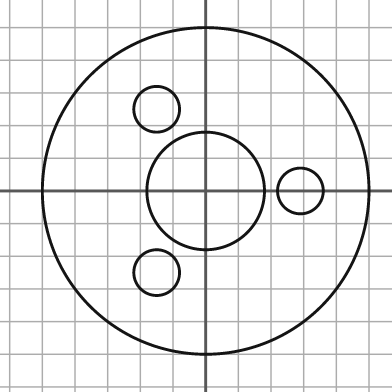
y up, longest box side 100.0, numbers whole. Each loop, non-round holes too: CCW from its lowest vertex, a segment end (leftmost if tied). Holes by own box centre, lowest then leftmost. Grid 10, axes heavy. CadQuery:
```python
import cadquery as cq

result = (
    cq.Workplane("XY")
    .moveTo(0.0, 0.0)
    .circle(50.0)
    .moveTo(-15.0, -25.0)
    .circle(7.0)
    .moveTo(0.0, 0.0)
    .circle(18.0)
    .moveTo(29.0, 0.0)
    .circle(7.0)
    .moveTo(-15.0, 25.0)
    .circle(7.0)
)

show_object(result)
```